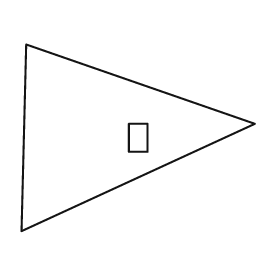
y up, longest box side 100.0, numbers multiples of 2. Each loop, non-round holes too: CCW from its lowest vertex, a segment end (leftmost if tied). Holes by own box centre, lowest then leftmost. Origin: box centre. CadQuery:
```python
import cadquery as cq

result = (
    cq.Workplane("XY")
    .moveTo(-50.0, -40.0)
    .lineTo(50.0, 6.0)
    .lineTo(-48.0, 40.0)
    .close()
    .moveTo(-4.0, -6.0)
    .lineTo(4.0, -6.0)
    .lineTo(4.0, 6.0)
    .lineTo(-4.0, 6.0)
    .close()
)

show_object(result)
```